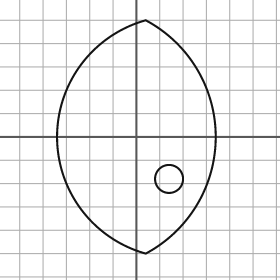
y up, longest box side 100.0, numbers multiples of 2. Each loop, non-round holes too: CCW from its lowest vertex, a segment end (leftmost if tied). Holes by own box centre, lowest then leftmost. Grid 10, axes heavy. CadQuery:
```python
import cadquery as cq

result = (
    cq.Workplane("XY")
    .moveTo(4.0, -50.0)
    .threePointArc((34.0, 0.0), (4.0, 50.0))
    .threePointArc((-34.0, 0.0), (4.0, -50.0))
    .close()
    .moveTo(14.0, -18.0)
    .circle(6.0)
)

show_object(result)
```